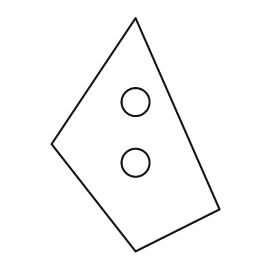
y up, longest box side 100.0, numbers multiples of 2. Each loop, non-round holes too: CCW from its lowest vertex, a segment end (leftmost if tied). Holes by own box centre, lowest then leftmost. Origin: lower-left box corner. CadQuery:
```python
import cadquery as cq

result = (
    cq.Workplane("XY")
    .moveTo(36.0, 0.0)
    .lineTo(72.0, 18.0)
    .lineTo(36.0, 100.0)
    .lineTo(0.0, 46.0)
    .close()
    .moveTo(36.0, 38.0)
    .circle(6.0)
    .moveTo(36.0, 64.0)
    .circle(6.0)
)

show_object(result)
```